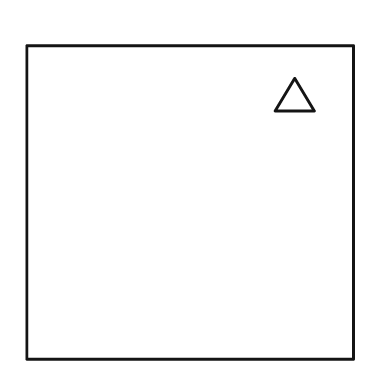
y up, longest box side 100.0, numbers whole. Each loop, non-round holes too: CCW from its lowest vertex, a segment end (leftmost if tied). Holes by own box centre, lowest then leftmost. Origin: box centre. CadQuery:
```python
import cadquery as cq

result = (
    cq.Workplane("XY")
    .moveTo(-50.0, -48.0)
    .lineTo(50.0, -48.0)
    .lineTo(50.0, 48.0)
    .lineTo(-50.0, 48.0)
    .close()
    .moveTo(26.0, 28.0)
    .lineTo(38.0, 28.0)
    .lineTo(32.0, 38.0)
    .close()
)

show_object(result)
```